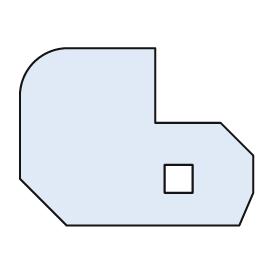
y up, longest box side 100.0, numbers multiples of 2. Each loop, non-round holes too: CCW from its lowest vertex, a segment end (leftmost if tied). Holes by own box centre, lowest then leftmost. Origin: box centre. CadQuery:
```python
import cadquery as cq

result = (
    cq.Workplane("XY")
    .moveTo(-30.0, -38.0)
    .lineTo(44.0, -38.0)
    .lineTo(50.0, -24.0)
    .lineTo(50.0, -8.0)
    .lineTo(36.0, 6.0)
    .lineTo(8.0, 6.0)
    .lineTo(8.0, 38.0)
    .lineTo(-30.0, 38.0)
    .threePointArc((-44.0, 32.0), (-50.0, 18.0))
    .lineTo(-50.0, -18.0)
    .close()
    .moveTo(12.0, -24.0)
    .lineTo(24.0, -24.0)
    .lineTo(24.0, -12.0)
    .lineTo(12.0, -12.0)
    .close()
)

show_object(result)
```